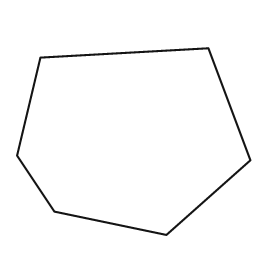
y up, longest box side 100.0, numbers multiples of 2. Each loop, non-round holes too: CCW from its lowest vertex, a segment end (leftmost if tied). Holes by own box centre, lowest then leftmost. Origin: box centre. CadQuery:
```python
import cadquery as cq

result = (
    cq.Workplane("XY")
    .moveTo(14.0, -40.0)
    .lineTo(50.0, -8.0)
    .lineTo(32.0, 40.0)
    .lineTo(-40.0, 36.0)
    .lineTo(-50.0, -6.0)
    .lineTo(-34.0, -30.0)
    .close()
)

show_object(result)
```